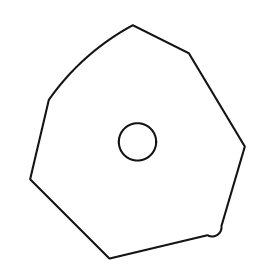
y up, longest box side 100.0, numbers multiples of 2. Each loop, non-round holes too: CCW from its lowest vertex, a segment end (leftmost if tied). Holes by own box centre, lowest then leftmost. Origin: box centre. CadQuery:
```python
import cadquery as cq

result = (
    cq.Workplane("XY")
    .moveTo(-12.0, -50.0)
    .lineTo(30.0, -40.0)
    .threePointArc((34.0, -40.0), (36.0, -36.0))
    .lineTo(46.0, -2.0)
    .lineTo(22.0, 38.0)
    .lineTo(-2.0, 50.0)
    .threePointArc((-22.0, 36.0), (-38.0, 18.0))
    .lineTo(-46.0, -16.0)
    .close()
    .moveTo(0.0, 0.0)
    .circle(8.0)
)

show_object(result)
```